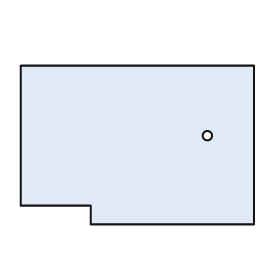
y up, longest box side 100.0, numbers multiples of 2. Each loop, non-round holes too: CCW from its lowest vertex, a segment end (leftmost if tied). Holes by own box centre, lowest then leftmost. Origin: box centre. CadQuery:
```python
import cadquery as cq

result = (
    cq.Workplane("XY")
    .moveTo(-20.0, -34.0)
    .lineTo(50.0, -34.0)
    .lineTo(50.0, 34.0)
    .lineTo(-50.0, 34.0)
    .lineTo(-50.0, -26.0)
    .lineTo(-20.0, -26.0)
    .close()
    .moveTo(30.0, 4.0)
    .circle(2.0)
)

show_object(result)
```